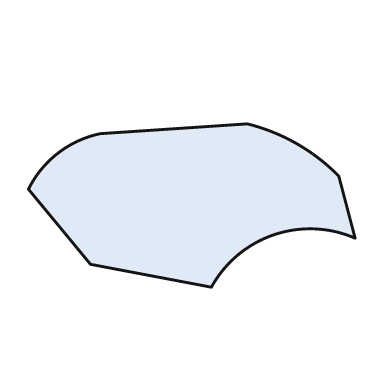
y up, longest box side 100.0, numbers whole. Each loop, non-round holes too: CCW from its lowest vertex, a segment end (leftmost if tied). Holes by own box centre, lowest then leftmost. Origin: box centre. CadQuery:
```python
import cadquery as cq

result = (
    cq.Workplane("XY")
    .moveTo(6.0, -25.0)
    .threePointArc((25.0, -9.0), (50.0, -10.0))
    .lineTo(45.0, 9.0)
    .threePointArc((32.0, 19.0), (17.0, 25.0))
    .lineTo(-28.0, 22.0)
    .threePointArc((-41.0, 16.0), (-50.0, 5.0))
    .lineTo(-31.0, -18.0)
    .close()
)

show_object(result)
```